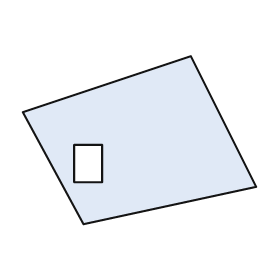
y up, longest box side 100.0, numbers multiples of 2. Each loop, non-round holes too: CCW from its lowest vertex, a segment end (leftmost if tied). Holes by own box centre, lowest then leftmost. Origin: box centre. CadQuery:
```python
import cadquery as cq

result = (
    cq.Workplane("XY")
    .moveTo(-24.0, -36.0)
    .lineTo(50.0, -20.0)
    .lineTo(22.0, 36.0)
    .lineTo(-50.0, 12.0)
    .close()
    .moveTo(-28.0, -18.0)
    .lineTo(-16.0, -18.0)
    .lineTo(-16.0, -2.0)
    .lineTo(-28.0, -2.0)
    .close()
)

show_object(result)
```